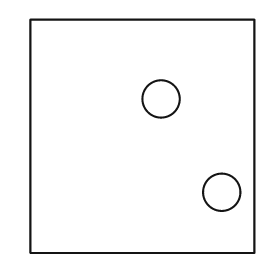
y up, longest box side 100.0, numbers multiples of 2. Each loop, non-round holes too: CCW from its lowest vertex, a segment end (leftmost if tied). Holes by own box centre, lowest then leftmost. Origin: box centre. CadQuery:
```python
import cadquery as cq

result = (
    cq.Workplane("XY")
    .moveTo(-48.0, -50.0)
    .lineTo(48.0, -50.0)
    .lineTo(48.0, 50.0)
    .lineTo(-48.0, 50.0)
    .close()
    .moveTo(34.0, -24.0)
    .circle(8.0)
    .moveTo(8.0, 16.0)
    .circle(8.0)
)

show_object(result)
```